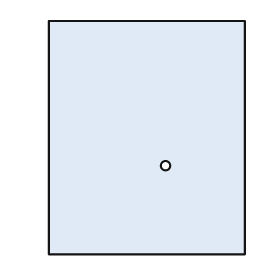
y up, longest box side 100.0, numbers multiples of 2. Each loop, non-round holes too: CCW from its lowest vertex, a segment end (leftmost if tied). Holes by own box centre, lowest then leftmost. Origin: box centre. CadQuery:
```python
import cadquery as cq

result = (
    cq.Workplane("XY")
    .moveTo(-42.0, -50.0)
    .lineTo(42.0, -50.0)
    .lineTo(42.0, 50.0)
    .lineTo(-42.0, 50.0)
    .close()
    .moveTo(8.0, -12.0)
    .circle(2.0)
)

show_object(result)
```